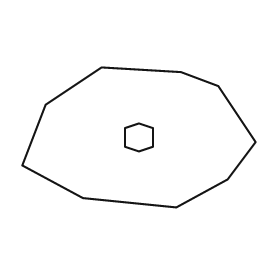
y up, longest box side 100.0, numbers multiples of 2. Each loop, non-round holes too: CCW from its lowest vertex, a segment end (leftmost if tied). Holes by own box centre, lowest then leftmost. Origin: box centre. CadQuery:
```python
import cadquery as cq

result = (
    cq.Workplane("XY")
    .moveTo(16.0, -30.0)
    .lineTo(38.0, -18.0)
    .lineTo(50.0, -2.0)
    .lineTo(34.0, 22.0)
    .lineTo(18.0, 28.0)
    .lineTo(-16.0, 30.0)
    .lineTo(-40.0, 14.0)
    .lineTo(-50.0, -12.0)
    .lineTo(-24.0, -26.0)
    .close()
    .moveTo(0.0, -6.0)
    .lineTo(6.0, -4.0)
    .lineTo(6.0, 4.0)
    .lineTo(0.0, 6.0)
    .lineTo(-6.0, 4.0)
    .lineTo(-6.0, -4.0)
    .close()
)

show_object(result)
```